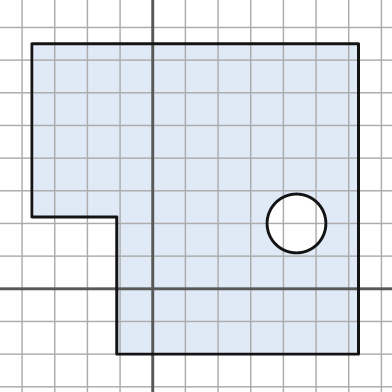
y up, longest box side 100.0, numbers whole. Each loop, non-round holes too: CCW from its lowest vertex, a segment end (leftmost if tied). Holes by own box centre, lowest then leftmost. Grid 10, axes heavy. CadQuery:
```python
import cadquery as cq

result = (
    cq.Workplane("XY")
    .moveTo(-11.0, -20.0)
    .lineTo(63.0, -20.0)
    .lineTo(63.0, 75.0)
    .lineTo(-37.0, 75.0)
    .lineTo(-37.0, 22.0)
    .lineTo(-11.0, 22.0)
    .close()
    .moveTo(44.0, 20.0)
    .circle(9.0)
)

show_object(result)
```